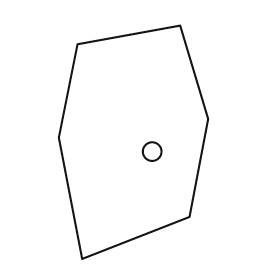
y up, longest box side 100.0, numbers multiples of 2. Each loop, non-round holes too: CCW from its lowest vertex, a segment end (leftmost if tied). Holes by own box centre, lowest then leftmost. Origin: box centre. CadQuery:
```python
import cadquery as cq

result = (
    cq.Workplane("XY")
    .moveTo(-22.0, -50.0)
    .lineTo(24.0, -32.0)
    .lineTo(32.0, 10.0)
    .lineTo(20.0, 50.0)
    .lineTo(-24.0, 42.0)
    .lineTo(-32.0, 2.0)
    .close()
    .moveTo(8.0, -4.0)
    .circle(4.0)
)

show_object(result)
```